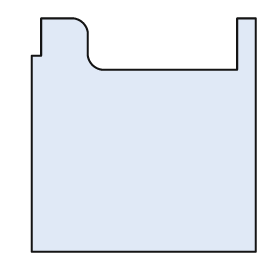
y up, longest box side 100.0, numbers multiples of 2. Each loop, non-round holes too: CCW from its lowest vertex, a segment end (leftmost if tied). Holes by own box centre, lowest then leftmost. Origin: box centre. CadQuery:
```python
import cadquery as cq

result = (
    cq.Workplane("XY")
    .moveTo(-48.0, -50.0)
    .lineTo(48.0, -50.0)
    .lineTo(48.0, 50.0)
    .lineTo(40.0, 50.0)
    .lineTo(40.0, 28.0)
    .lineTo(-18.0, 28.0)
    .threePointArc((-22.0, 30.0), (-24.0, 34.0))
    .lineTo(-24.0, 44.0)
    .threePointArc((-26.0, 48.0), (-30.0, 50.0))
    .lineTo(-44.0, 50.0)
    .lineTo(-44.0, 34.0)
    .lineTo(-48.0, 34.0)
    .close()
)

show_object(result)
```